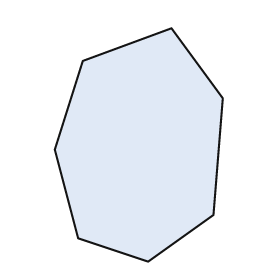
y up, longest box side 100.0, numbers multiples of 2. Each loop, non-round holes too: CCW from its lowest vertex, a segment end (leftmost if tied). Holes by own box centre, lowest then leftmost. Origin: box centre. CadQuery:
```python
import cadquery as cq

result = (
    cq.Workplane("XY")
    .moveTo(4.0, -50.0)
    .lineTo(32.0, -30.0)
    .lineTo(36.0, 20.0)
    .lineTo(14.0, 50.0)
    .lineTo(-24.0, 36.0)
    .lineTo(-36.0, -2.0)
    .lineTo(-26.0, -40.0)
    .close()
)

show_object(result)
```